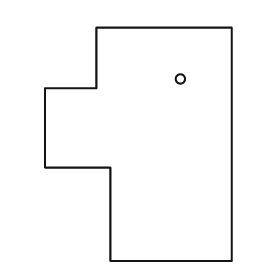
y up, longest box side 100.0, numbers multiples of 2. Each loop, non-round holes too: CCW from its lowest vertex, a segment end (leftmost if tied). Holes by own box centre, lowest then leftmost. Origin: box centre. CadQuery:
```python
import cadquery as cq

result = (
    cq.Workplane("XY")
    .moveTo(-12.0, -50.0)
    .lineTo(40.0, -50.0)
    .lineTo(40.0, 50.0)
    .lineTo(-18.0, 50.0)
    .lineTo(-18.0, 24.0)
    .lineTo(-40.0, 24.0)
    .lineTo(-40.0, -10.0)
    .lineTo(-12.0, -10.0)
    .close()
    .moveTo(18.0, 28.0)
    .circle(2.0)
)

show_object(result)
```